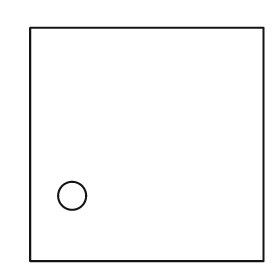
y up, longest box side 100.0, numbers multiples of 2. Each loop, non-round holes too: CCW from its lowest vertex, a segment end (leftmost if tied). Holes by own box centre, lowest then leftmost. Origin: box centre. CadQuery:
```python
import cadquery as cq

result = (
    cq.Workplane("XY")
    .moveTo(-50.0, -50.0)
    .lineTo(50.0, -50.0)
    .lineTo(50.0, 50.0)
    .lineTo(-50.0, 50.0)
    .close()
    .moveTo(-32.0, -22.0)
    .circle(6.0)
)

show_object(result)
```